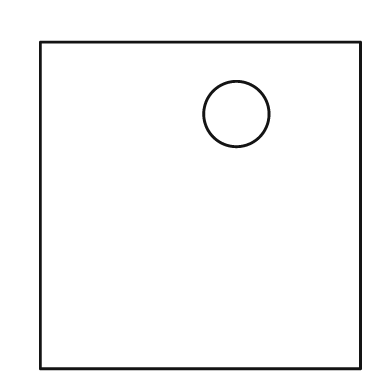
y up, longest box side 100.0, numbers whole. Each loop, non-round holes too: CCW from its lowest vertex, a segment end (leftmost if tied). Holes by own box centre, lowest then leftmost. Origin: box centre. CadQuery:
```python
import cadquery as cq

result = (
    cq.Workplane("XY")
    .moveTo(-49.0, -50.0)
    .lineTo(49.0, -50.0)
    .lineTo(49.0, 50.0)
    .lineTo(-49.0, 50.0)
    .close()
    .moveTo(11.0, 28.0)
    .circle(10.0)
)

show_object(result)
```